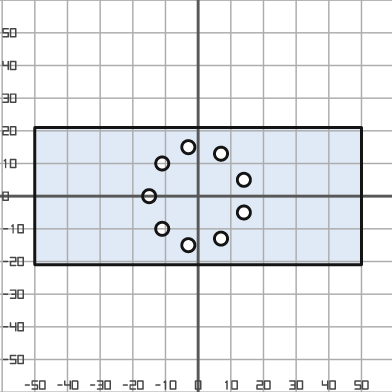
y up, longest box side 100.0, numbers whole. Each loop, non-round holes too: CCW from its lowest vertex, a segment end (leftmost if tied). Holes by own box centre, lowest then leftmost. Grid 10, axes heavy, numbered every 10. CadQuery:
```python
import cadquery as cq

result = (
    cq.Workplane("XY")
    .moveTo(-50.0, -21.0)
    .lineTo(50.0, -21.0)
    .lineTo(50.0, 21.0)
    .lineTo(-50.0, 21.0)
    .close()
    .moveTo(-3.0, -15.0)
    .circle(2.0)
    .moveTo(7.0, -13.0)
    .circle(2.0)
    .moveTo(-11.0, -10.0)
    .circle(2.0)
    .moveTo(14.0, -5.0)
    .circle(2.0)
    .moveTo(-15.0, 0.0)
    .circle(2.0)
    .moveTo(14.0, 5.0)
    .circle(2.0)
    .moveTo(-11.0, 10.0)
    .circle(2.0)
    .moveTo(7.0, 13.0)
    .circle(2.0)
    .moveTo(-3.0, 15.0)
    .circle(2.0)
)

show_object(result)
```